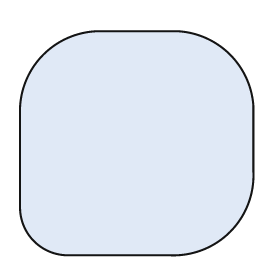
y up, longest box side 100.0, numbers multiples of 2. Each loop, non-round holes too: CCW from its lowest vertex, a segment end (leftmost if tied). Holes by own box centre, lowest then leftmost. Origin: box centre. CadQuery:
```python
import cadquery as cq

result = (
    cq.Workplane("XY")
    .moveTo(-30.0, -48.0)
    .lineTo(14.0, -48.0)
    .threePointArc((40.0, -38.0), (50.0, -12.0))
    .lineTo(50.0, 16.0)
    .threePointArc((40.0, 38.0), (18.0, 48.0))
    .lineTo(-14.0, 48.0)
    .threePointArc((-40.0, 38.0), (-50.0, 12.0))
    .lineTo(-50.0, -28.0)
    .threePointArc((-44.0, -42.0), (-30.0, -48.0))
    .close()
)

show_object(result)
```